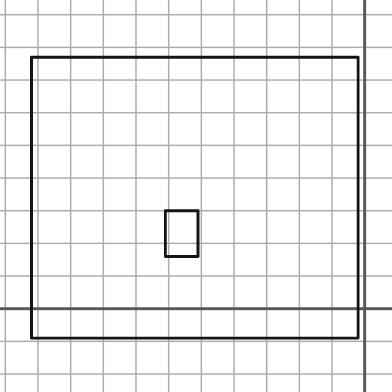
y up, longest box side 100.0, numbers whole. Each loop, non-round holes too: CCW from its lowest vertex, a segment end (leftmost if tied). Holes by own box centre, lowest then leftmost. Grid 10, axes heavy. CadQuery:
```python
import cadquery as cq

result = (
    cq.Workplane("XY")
    .moveTo(-102.0, -9.0)
    .lineTo(-2.0, -9.0)
    .lineTo(-2.0, 77.0)
    .lineTo(-102.0, 77.0)
    .close()
    .moveTo(-61.0, 16.0)
    .lineTo(-51.0, 16.0)
    .lineTo(-51.0, 30.0)
    .lineTo(-61.0, 30.0)
    .close()
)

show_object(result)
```